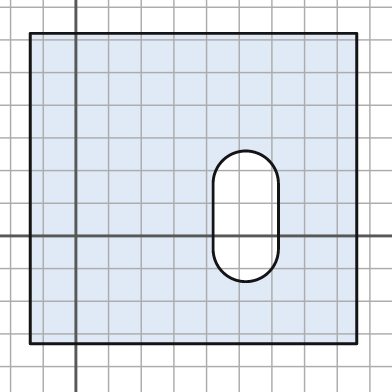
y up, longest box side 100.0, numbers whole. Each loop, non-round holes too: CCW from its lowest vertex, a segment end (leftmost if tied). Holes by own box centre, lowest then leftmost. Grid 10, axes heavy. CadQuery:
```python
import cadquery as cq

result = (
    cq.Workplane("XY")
    .moveTo(-14.0, -33.0)
    .lineTo(86.0, -33.0)
    .lineTo(86.0, 62.0)
    .lineTo(-14.0, 62.0)
    .close()
    .moveTo(42.0, -4.0)
    .threePointArc((52.0, -14.0), (62.0, -4.0))
    .lineTo(62.0, 16.0)
    .threePointArc((52.0, 26.0), (42.0, 16.0))
    .close()
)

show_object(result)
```